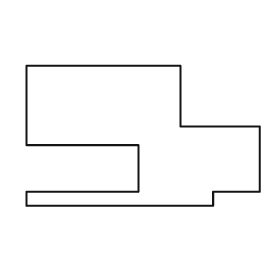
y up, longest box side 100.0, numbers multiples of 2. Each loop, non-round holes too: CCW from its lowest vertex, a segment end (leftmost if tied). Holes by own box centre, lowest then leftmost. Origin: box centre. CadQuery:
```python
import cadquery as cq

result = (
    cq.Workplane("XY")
    .moveTo(-50.0, -30.0)
    .lineTo(30.0, -30.0)
    .lineTo(30.0, -24.0)
    .lineTo(50.0, -24.0)
    .lineTo(50.0, 4.0)
    .lineTo(16.0, 4.0)
    .lineTo(16.0, 30.0)
    .lineTo(-50.0, 30.0)
    .lineTo(-50.0, -4.0)
    .lineTo(-2.0, -4.0)
    .lineTo(-2.0, -24.0)
    .lineTo(-50.0, -24.0)
    .close()
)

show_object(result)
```